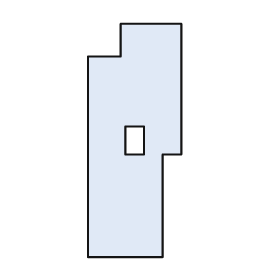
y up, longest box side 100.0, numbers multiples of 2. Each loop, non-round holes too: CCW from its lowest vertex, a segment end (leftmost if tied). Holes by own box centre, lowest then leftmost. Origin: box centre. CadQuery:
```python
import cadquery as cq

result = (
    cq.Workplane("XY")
    .moveTo(-20.0, -50.0)
    .lineTo(12.0, -50.0)
    .lineTo(12.0, -6.0)
    .lineTo(20.0, -6.0)
    .lineTo(20.0, 50.0)
    .lineTo(-6.0, 50.0)
    .lineTo(-6.0, 36.0)
    .lineTo(-20.0, 36.0)
    .close()
    .moveTo(-4.0, -6.0)
    .lineTo(4.0, -6.0)
    .lineTo(4.0, 6.0)
    .lineTo(-4.0, 6.0)
    .close()
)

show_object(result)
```